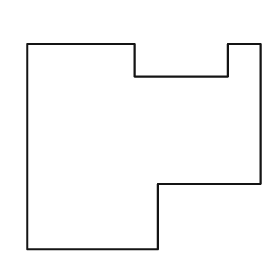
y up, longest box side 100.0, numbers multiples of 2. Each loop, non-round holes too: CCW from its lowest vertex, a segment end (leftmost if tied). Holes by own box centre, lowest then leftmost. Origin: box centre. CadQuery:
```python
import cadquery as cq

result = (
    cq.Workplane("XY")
    .moveTo(-50.0, -44.0)
    .lineTo(6.0, -44.0)
    .lineTo(6.0, -16.0)
    .lineTo(50.0, -16.0)
    .lineTo(50.0, 44.0)
    .lineTo(36.0, 44.0)
    .lineTo(36.0, 30.0)
    .lineTo(-4.0, 30.0)
    .lineTo(-4.0, 44.0)
    .lineTo(-50.0, 44.0)
    .close()
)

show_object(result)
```